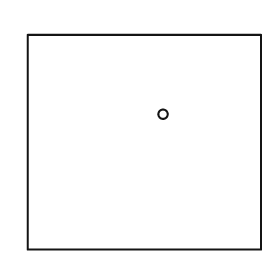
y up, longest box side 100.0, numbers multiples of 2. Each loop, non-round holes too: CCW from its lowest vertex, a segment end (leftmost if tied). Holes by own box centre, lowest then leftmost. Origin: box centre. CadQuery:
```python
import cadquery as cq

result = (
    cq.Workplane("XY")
    .moveTo(-50.0, -46.0)
    .lineTo(50.0, -46.0)
    .lineTo(50.0, 46.0)
    .lineTo(-50.0, 46.0)
    .close()
    .moveTo(8.0, 12.0)
    .circle(2.0)
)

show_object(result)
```